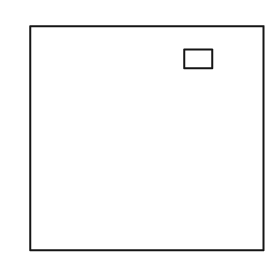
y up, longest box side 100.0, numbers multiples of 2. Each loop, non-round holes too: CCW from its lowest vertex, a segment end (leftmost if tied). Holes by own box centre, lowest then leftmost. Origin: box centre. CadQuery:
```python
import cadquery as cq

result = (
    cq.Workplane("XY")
    .moveTo(-50.0, -48.0)
    .lineTo(50.0, -48.0)
    .lineTo(50.0, 48.0)
    .lineTo(-50.0, 48.0)
    .close()
    .moveTo(16.0, 30.0)
    .lineTo(28.0, 30.0)
    .lineTo(28.0, 38.0)
    .lineTo(16.0, 38.0)
    .close()
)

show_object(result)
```